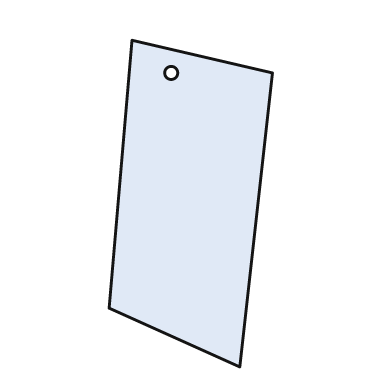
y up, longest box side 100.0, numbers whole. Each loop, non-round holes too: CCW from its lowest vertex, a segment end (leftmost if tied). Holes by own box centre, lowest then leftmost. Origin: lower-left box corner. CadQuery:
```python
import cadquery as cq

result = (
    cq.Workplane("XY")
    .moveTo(40.0, 0.0)
    .lineTo(50.0, 90.0)
    .lineTo(7.0, 100.0)
    .lineTo(0.0, 18.0)
    .close()
    .moveTo(19.0, 90.0)
    .circle(2.0)
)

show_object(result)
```